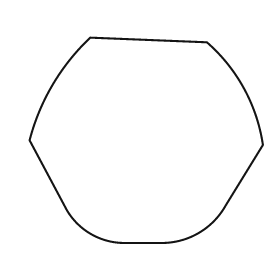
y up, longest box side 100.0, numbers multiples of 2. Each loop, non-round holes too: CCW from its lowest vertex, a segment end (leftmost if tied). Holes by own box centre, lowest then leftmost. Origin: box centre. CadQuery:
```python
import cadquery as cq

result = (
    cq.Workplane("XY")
    .moveTo(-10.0, -44.0)
    .lineTo(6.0, -44.0)
    .threePointArc((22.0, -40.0), (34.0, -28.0))
    .lineTo(50.0, -2.0)
    .threePointArc((42.0, 22.0), (26.0, 42.0))
    .lineTo(-24.0, 44.0)
    .threePointArc((-40.0, 24.0), (-50.0, 0.0))
    .lineTo(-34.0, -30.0)
    .threePointArc((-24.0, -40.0), (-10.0, -44.0))
    .close()
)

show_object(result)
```